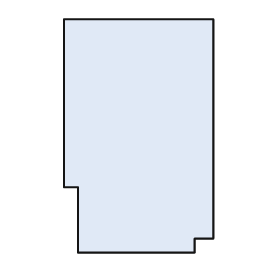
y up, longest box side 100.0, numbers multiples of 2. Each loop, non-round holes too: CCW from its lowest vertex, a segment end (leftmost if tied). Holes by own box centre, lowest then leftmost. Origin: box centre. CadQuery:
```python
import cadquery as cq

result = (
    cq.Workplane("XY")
    .moveTo(-26.0, -50.0)
    .lineTo(24.0, -50.0)
    .lineTo(24.0, -44.0)
    .lineTo(32.0, -44.0)
    .lineTo(32.0, 50.0)
    .lineTo(-32.0, 50.0)
    .lineTo(-32.0, -22.0)
    .lineTo(-26.0, -22.0)
    .close()
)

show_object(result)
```